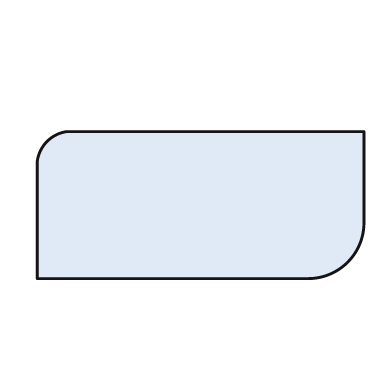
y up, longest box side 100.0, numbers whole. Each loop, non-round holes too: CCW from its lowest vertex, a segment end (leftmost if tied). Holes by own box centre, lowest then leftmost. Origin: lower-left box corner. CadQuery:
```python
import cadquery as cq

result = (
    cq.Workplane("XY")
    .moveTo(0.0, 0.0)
    .lineTo(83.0, 0.0)
    .threePointArc((95.0, 5.0), (100.0, 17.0))
    .lineTo(100.0, 45.0)
    .lineTo(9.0, 45.0)
    .threePointArc((3.0, 42.0), (0.0, 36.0))
    .close()
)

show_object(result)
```